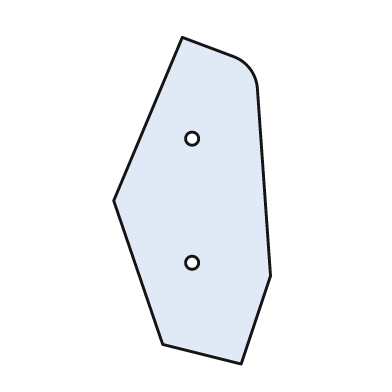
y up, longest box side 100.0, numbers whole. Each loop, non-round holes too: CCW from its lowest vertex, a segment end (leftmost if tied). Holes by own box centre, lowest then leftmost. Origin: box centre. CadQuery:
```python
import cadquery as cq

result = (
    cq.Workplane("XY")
    .moveTo(15.0, -50.0)
    .lineTo(24.0, -23.0)
    .lineTo(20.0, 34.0)
    .threePointArc((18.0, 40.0), (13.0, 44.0))
    .lineTo(-3.0, 50.0)
    .lineTo(-24.0, 0.0)
    .lineTo(-9.0, -44.0)
    .close()
    .moveTo(0.0, -19.0)
    .circle(2.0)
    .moveTo(0.0, 19.0)
    .circle(2.0)
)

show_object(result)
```